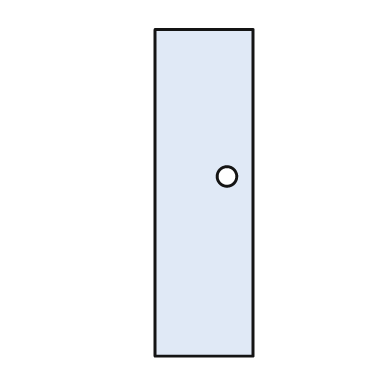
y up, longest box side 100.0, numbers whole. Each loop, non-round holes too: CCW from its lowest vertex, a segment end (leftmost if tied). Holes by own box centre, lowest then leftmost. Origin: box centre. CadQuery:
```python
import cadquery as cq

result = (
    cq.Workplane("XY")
    .moveTo(-15.0, -50.0)
    .lineTo(15.0, -50.0)
    .lineTo(15.0, 50.0)
    .lineTo(-15.0, 50.0)
    .close()
    .moveTo(7.0, 5.0)
    .circle(3.0)
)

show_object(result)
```